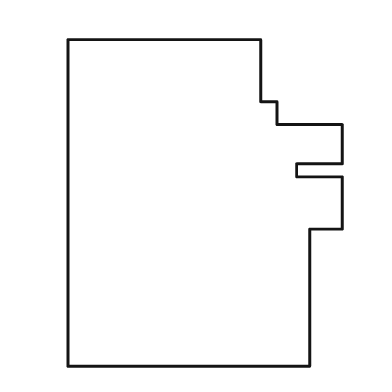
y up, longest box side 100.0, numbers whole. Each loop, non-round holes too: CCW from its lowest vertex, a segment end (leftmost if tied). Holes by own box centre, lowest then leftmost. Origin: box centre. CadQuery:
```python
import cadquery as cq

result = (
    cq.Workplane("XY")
    .moveTo(-42.0, -50.0)
    .lineTo(32.0, -50.0)
    .lineTo(32.0, -8.0)
    .lineTo(42.0, -8.0)
    .lineTo(42.0, 8.0)
    .lineTo(28.0, 8.0)
    .lineTo(28.0, 12.0)
    .lineTo(42.0, 12.0)
    .lineTo(42.0, 24.0)
    .lineTo(22.0, 24.0)
    .lineTo(22.0, 31.0)
    .lineTo(17.0, 31.0)
    .lineTo(17.0, 50.0)
    .lineTo(-42.0, 50.0)
    .close()
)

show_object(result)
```